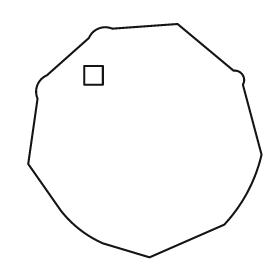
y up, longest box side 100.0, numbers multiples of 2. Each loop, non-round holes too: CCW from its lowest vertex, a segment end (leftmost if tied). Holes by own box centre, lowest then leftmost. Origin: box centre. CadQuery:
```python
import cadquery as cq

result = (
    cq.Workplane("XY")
    .moveTo(2.0, -50.0)
    .lineTo(34.0, -36.0)
    .threePointArc((44.0, -22.0), (50.0, -6.0))
    .lineTo(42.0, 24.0)
    .threePointArc((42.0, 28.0), (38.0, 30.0))
    .lineTo(14.0, 50.0)
    .lineTo(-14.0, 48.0)
    .threePointArc((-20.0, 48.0), (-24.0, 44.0))
    .lineTo(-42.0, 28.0)
    .threePointArc((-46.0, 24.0), (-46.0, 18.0))
    .lineTo(-50.0, -10.0)
    .lineTo(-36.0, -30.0)
    .threePointArc((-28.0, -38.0), (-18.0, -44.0))
    .close()
    .moveTo(-26.0, 24.0)
    .lineTo(-18.0, 24.0)
    .lineTo(-18.0, 32.0)
    .lineTo(-26.0, 32.0)
    .close()
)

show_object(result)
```